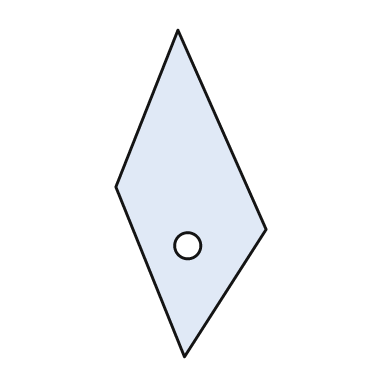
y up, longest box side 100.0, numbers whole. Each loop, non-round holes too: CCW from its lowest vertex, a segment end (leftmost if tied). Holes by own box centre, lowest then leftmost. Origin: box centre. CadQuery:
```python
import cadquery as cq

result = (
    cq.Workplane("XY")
    .moveTo(-2.0, -50.0)
    .lineTo(23.0, -11.0)
    .lineTo(-4.0, 50.0)
    .lineTo(-23.0, 2.0)
    .close()
    .moveTo(-1.0, -16.0)
    .circle(4.0)
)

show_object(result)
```